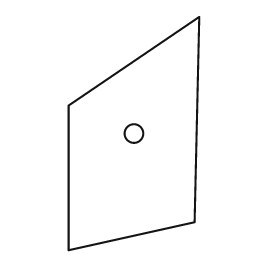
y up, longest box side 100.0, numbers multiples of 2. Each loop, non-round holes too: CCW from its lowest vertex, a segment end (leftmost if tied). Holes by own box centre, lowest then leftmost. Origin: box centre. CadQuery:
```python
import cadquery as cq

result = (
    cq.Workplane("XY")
    .moveTo(-28.0, -50.0)
    .lineTo(26.0, -38.0)
    .lineTo(28.0, 50.0)
    .lineTo(-28.0, 12.0)
    .close()
    .moveTo(0.0, 0.0)
    .circle(4.0)
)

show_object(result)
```